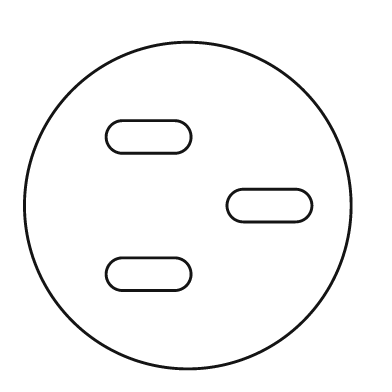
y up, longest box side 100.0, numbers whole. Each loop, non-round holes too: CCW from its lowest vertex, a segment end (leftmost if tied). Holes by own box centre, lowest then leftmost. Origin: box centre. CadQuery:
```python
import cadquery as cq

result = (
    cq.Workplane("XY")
    .moveTo(0.0, 0.0)
    .circle(50.0)
    .moveTo(-20.0, -26.0)
    .lineTo(-4.0, -26.0)
    .threePointArc((1.0, -21.0), (-4.0, -16.0))
    .lineTo(-20.0, -16.0)
    .threePointArc((-25.0, -21.0), (-20.0, -26.0))
    .close()
    .moveTo(17.0, -5.0)
    .lineTo(33.0, -5.0)
    .threePointArc((38.0, 0.0), (33.0, 5.0))
    .lineTo(17.0, 5.0)
    .threePointArc((12.0, 0.0), (17.0, -5.0))
    .close()
    .moveTo(-20.0, 16.0)
    .lineTo(-4.0, 16.0)
    .threePointArc((1.0, 21.0), (-4.0, 26.0))
    .lineTo(-20.0, 26.0)
    .threePointArc((-25.0, 21.0), (-20.0, 16.0))
    .close()
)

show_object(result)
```